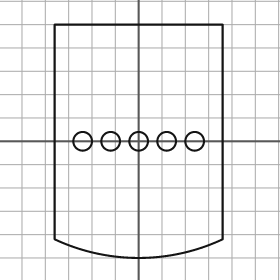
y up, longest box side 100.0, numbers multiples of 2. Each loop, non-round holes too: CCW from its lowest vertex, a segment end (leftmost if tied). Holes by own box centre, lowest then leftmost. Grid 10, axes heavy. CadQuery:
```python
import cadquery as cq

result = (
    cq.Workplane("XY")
    .moveTo(-36.0, -42.0)
    .threePointArc((0.0, -50.0), (36.0, -42.0))
    .lineTo(36.0, 50.0)
    .lineTo(-36.0, 50.0)
    .close()
    .moveTo(-24.0, 0.0)
    .circle(4.0)
    .moveTo(-12.0, 0.0)
    .circle(4.0)
    .moveTo(0.0, 0.0)
    .circle(4.0)
    .moveTo(12.0, 0.0)
    .circle(4.0)
    .moveTo(24.0, 0.0)
    .circle(4.0)
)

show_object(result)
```